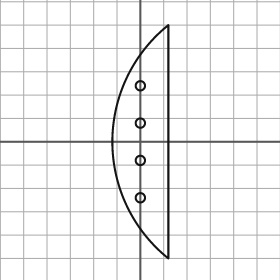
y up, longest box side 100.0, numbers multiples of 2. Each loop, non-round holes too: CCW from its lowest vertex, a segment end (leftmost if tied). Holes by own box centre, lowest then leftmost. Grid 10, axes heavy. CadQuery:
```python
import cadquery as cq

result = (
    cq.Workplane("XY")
    .moveTo(12.0, -50.0)
    .lineTo(12.0, 50.0)
    .threePointArc((-12.0, 0.0), (12.0, -50.0))
    .close()
    .moveTo(0.0, -24.0)
    .circle(2.0)
    .moveTo(0.0, -8.0)
    .circle(2.0)
    .moveTo(0.0, 8.0)
    .circle(2.0)
    .moveTo(0.0, 24.0)
    .circle(2.0)
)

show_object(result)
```